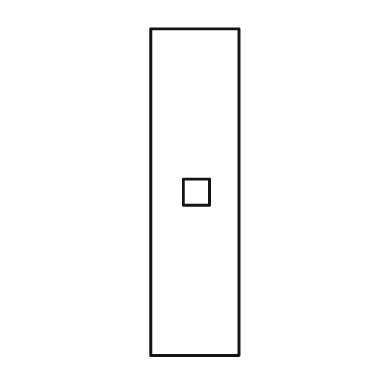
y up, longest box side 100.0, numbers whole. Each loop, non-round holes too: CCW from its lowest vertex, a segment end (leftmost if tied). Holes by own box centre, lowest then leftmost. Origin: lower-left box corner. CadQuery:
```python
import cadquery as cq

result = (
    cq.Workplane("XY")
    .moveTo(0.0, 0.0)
    .lineTo(27.0, 0.0)
    .lineTo(27.0, 100.0)
    .lineTo(0.0, 100.0)
    .close()
    .moveTo(10.0, 46.0)
    .lineTo(18.0, 46.0)
    .lineTo(18.0, 54.0)
    .lineTo(10.0, 54.0)
    .close()
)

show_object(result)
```